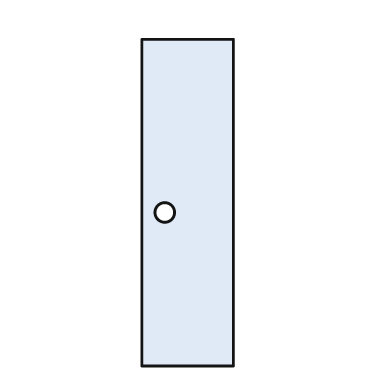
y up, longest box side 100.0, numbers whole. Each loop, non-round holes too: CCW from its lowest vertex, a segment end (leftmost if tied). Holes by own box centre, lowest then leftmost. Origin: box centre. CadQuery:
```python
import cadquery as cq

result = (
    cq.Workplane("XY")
    .moveTo(-14.0, -50.0)
    .lineTo(14.0, -50.0)
    .lineTo(14.0, 50.0)
    .lineTo(-14.0, 50.0)
    .close()
    .moveTo(-7.0, -3.0)
    .circle(3.0)
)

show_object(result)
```